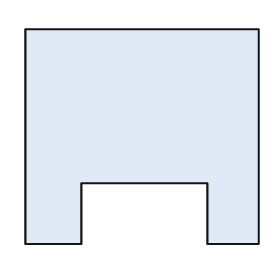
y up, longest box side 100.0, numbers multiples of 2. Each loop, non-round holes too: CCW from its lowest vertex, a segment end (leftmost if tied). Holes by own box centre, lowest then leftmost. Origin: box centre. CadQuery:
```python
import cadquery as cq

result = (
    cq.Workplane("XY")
    .moveTo(-50.0, -46.0)
    .lineTo(-26.0, -46.0)
    .lineTo(-26.0, -20.0)
    .lineTo(28.0, -20.0)
    .lineTo(28.0, -46.0)
    .lineTo(50.0, -46.0)
    .lineTo(50.0, 46.0)
    .lineTo(-50.0, 46.0)
    .close()
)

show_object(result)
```